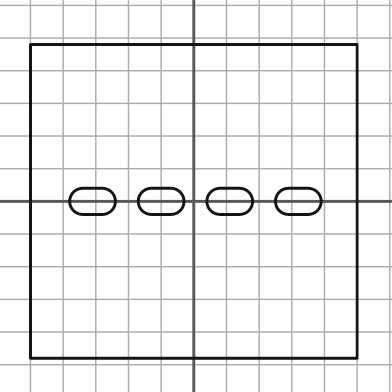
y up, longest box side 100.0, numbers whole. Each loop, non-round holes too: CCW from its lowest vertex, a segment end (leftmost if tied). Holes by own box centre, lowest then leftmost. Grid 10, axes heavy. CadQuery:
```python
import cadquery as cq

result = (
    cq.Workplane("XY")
    .moveTo(-50.0, -48.0)
    .lineTo(50.0, -48.0)
    .lineTo(50.0, 48.0)
    .lineTo(-50.0, 48.0)
    .close()
    .moveTo(-34.0, -4.0)
    .lineTo(-28.0, -4.0)
    .threePointArc((-24.0, 0.0), (-28.0, 4.0))
    .lineTo(-34.0, 4.0)
    .threePointArc((-38.0, 0.0), (-34.0, -4.0))
    .close()
    .moveTo(-13.0, -4.0)
    .lineTo(-7.0, -4.0)
    .threePointArc((-3.0, 0.0), (-7.0, 4.0))
    .lineTo(-13.0, 4.0)
    .threePointArc((-17.0, 0.0), (-13.0, -4.0))
    .close()
    .moveTo(8.0, -4.0)
    .lineTo(14.0, -4.0)
    .threePointArc((18.0, 0.0), (14.0, 4.0))
    .lineTo(8.0, 4.0)
    .threePointArc((4.0, 0.0), (8.0, -4.0))
    .close()
    .moveTo(29.0, -4.0)
    .lineTo(35.0, -4.0)
    .threePointArc((39.0, 0.0), (35.0, 4.0))
    .lineTo(29.0, 4.0)
    .threePointArc((25.0, 0.0), (29.0, -4.0))
    .close()
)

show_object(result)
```